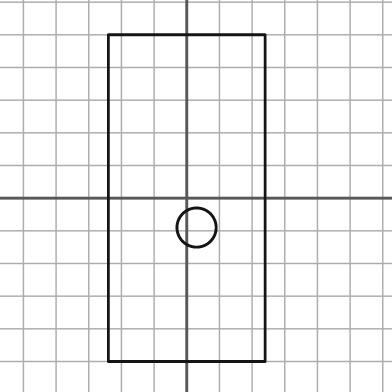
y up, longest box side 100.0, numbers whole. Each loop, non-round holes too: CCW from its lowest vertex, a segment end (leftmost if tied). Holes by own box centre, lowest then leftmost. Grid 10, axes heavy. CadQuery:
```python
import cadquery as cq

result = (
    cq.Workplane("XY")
    .moveTo(-24.0, -50.0)
    .lineTo(24.0, -50.0)
    .lineTo(24.0, 50.0)
    .lineTo(-24.0, 50.0)
    .close()
    .moveTo(3.0, -9.0)
    .circle(6.0)
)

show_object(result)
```